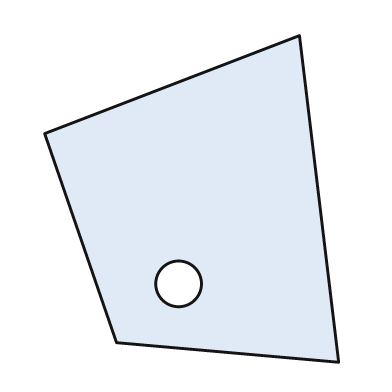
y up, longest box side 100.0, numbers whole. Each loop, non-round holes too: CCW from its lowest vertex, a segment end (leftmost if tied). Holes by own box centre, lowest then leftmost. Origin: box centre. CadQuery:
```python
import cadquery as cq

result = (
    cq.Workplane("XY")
    .moveTo(45.0, -50.0)
    .lineTo(33.0, 50.0)
    .lineTo(-45.0, 20.0)
    .lineTo(-23.0, -44.0)
    .close()
    .moveTo(-4.0, -26.0)
    .circle(7.0)
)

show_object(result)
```